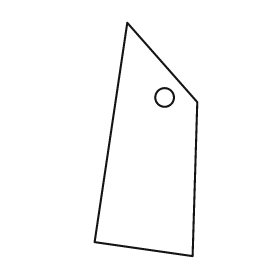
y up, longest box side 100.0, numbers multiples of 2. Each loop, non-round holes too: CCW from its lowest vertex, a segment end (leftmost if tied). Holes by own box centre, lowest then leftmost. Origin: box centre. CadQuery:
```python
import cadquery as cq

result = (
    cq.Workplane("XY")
    .moveTo(20.0, -50.0)
    .lineTo(22.0, 16.0)
    .lineTo(-8.0, 50.0)
    .lineTo(-22.0, -44.0)
    .close()
    .moveTo(8.0, 18.0)
    .circle(4.0)
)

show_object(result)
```